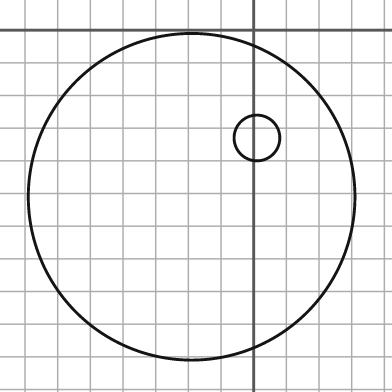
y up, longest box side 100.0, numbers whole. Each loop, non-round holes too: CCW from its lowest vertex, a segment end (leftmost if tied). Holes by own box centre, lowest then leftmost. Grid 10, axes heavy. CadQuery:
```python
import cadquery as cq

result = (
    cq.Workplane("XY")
    .moveTo(-19.0, -51.0)
    .circle(50.0)
    .moveTo(1.0, -33.0)
    .circle(7.0)
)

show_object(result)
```